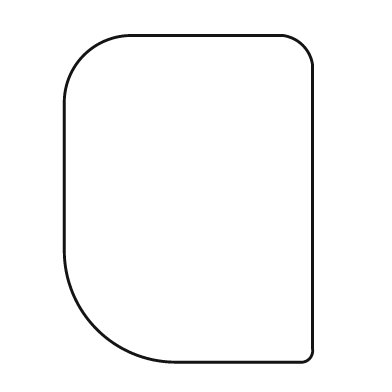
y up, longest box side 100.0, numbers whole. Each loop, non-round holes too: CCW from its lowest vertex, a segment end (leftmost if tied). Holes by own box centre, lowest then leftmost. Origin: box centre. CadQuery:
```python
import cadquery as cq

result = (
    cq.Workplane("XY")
    .moveTo(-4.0, -50.0)
    .lineTo(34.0, -50.0)
    .threePointArc((37.0, -49.0), (38.0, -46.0))
    .lineTo(38.0, 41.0)
    .threePointArc((35.0, 47.0), (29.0, 50.0))
    .lineTo(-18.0, 50.0)
    .threePointArc((-32.0, 44.0), (-38.0, 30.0))
    .lineTo(-38.0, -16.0)
    .threePointArc((-28.0, -40.0), (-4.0, -50.0))
    .close()
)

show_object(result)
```